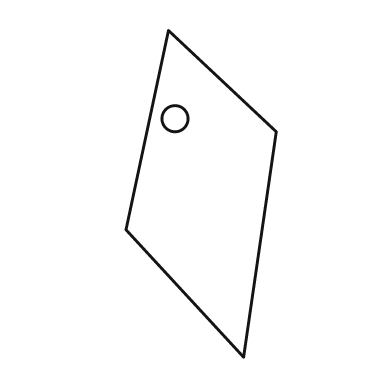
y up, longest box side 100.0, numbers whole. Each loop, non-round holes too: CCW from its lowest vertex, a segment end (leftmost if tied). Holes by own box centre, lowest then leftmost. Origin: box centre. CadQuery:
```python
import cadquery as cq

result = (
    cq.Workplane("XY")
    .moveTo(13.0, -50.0)
    .lineTo(23.0, 19.0)
    .lineTo(-10.0, 50.0)
    .lineTo(-23.0, -11.0)
    .close()
    .moveTo(-8.0, 23.0)
    .circle(4.0)
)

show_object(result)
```